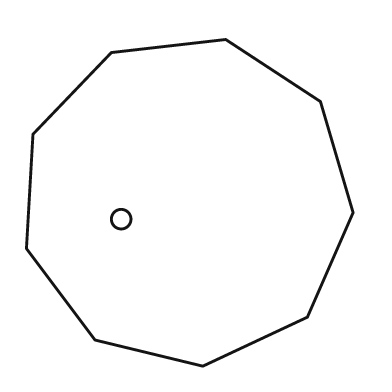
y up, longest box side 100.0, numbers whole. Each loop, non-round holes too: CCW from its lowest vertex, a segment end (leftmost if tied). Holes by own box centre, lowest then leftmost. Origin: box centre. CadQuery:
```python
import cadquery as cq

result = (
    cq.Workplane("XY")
    .moveTo(4.0, -50.0)
    .lineTo(36.0, -35.0)
    .lineTo(50.0, -3.0)
    .lineTo(40.0, 31.0)
    .lineTo(11.0, 50.0)
    .lineTo(-24.0, 46.0)
    .lineTo(-48.0, 21.0)
    .lineTo(-50.0, -14.0)
    .lineTo(-29.0, -42.0)
    .close()
    .moveTo(-21.0, -5.0)
    .circle(3.0)
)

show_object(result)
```